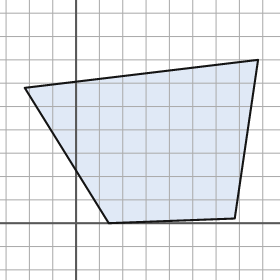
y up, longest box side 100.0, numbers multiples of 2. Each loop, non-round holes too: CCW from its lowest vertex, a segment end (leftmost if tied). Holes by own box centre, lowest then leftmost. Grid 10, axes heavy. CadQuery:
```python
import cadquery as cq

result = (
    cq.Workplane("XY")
    .moveTo(14.0, 0.0)
    .lineTo(68.0, 2.0)
    .lineTo(78.0, 70.0)
    .lineTo(-22.0, 58.0)
    .close()
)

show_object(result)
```